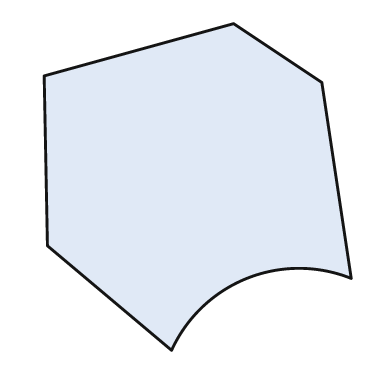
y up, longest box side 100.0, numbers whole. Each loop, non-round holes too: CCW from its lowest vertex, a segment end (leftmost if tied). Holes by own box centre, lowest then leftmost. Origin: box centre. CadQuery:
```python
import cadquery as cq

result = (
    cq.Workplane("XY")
    .moveTo(-8.0, -50.0)
    .threePointArc((15.0, -28.0), (47.0, -28.0))
    .lineTo(38.0, 32.0)
    .lineTo(11.0, 50.0)
    .lineTo(-47.0, 34.0)
    .lineTo(-46.0, -18.0)
    .close()
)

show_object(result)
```